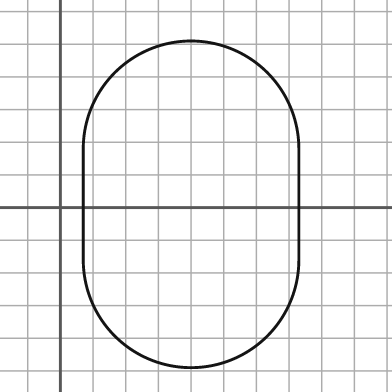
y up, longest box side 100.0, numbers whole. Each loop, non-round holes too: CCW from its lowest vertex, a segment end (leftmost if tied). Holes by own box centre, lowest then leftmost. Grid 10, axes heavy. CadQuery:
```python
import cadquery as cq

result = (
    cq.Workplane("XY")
    .moveTo(7.0, -16.0)
    .threePointArc((40.0, -49.0), (73.0, -16.0))
    .lineTo(73.0, 18.0)
    .threePointArc((40.0, 51.0), (7.0, 18.0))
    .close()
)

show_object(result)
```